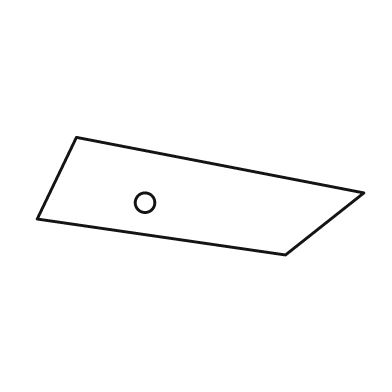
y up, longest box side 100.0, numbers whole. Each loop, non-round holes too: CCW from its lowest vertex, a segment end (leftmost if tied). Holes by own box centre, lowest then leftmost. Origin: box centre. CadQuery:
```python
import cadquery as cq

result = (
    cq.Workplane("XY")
    .moveTo(26.0, -18.0)
    .lineTo(50.0, 1.0)
    .lineTo(-38.0, 18.0)
    .lineTo(-50.0, -7.0)
    .close()
    .moveTo(-17.0, -2.0)
    .circle(3.0)
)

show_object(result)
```